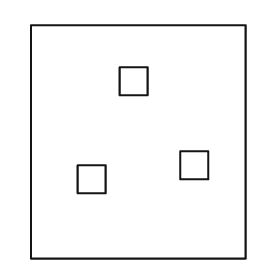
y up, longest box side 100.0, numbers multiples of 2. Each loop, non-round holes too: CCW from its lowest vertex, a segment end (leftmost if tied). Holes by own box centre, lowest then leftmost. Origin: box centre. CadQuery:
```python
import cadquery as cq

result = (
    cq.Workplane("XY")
    .moveTo(-46.0, -50.0)
    .lineTo(46.0, -50.0)
    .lineTo(46.0, 50.0)
    .lineTo(-46.0, 50.0)
    .close()
    .moveTo(-26.0, -22.0)
    .lineTo(-14.0, -22.0)
    .lineTo(-14.0, -10.0)
    .lineTo(-26.0, -10.0)
    .close()
    .moveTo(18.0, -16.0)
    .lineTo(30.0, -16.0)
    .lineTo(30.0, -4.0)
    .lineTo(18.0, -4.0)
    .close()
    .moveTo(-8.0, 20.0)
    .lineTo(4.0, 20.0)
    .lineTo(4.0, 32.0)
    .lineTo(-8.0, 32.0)
    .close()
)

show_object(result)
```